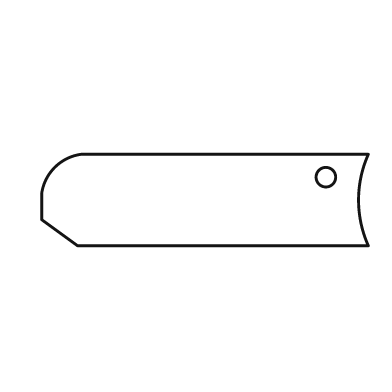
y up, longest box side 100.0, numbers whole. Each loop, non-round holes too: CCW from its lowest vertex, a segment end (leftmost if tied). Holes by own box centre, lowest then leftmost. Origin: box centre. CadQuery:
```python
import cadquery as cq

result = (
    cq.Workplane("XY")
    .moveTo(-39.0, -14.0)
    .lineTo(50.0, -14.0)
    .threePointArc((47.0, 0.0), (50.0, 14.0))
    .lineTo(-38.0, 14.0)
    .threePointArc((-46.0, 10.0), (-50.0, 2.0))
    .lineTo(-50.0, -6.0)
    .close()
    .moveTo(37.0, 7.0)
    .circle(3.0)
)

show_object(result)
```